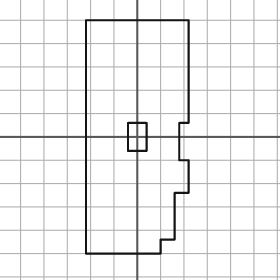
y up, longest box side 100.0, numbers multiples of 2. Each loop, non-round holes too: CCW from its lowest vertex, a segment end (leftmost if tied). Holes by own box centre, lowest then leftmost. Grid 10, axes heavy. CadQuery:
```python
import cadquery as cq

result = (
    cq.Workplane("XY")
    .moveTo(-22.0, -50.0)
    .lineTo(10.0, -50.0)
    .lineTo(10.0, -44.0)
    .lineTo(16.0, -44.0)
    .lineTo(16.0, -24.0)
    .lineTo(22.0, -24.0)
    .lineTo(22.0, -10.0)
    .lineTo(18.0, -10.0)
    .lineTo(18.0, 6.0)
    .lineTo(22.0, 6.0)
    .lineTo(22.0, 50.0)
    .lineTo(-22.0, 50.0)
    .close()
    .moveTo(-4.0, -6.0)
    .lineTo(4.0, -6.0)
    .lineTo(4.0, 6.0)
    .lineTo(-4.0, 6.0)
    .close()
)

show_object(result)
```